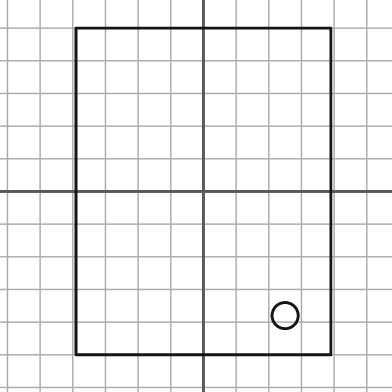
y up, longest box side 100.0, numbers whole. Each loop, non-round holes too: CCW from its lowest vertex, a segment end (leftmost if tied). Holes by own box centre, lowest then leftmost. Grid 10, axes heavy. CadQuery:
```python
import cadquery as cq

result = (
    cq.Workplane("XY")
    .moveTo(-39.0, -50.0)
    .lineTo(39.0, -50.0)
    .lineTo(39.0, 50.0)
    .lineTo(-39.0, 50.0)
    .close()
    .moveTo(25.0, -38.0)
    .circle(4.0)
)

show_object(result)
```